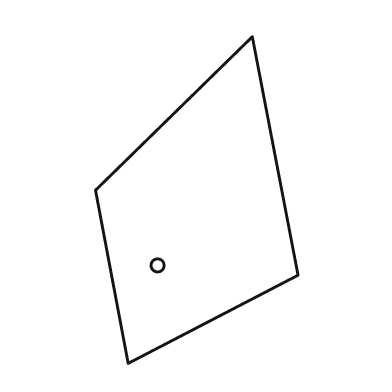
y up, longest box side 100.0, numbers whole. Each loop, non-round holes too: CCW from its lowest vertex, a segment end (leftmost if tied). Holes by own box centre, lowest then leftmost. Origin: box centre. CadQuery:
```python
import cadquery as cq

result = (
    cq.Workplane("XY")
    .moveTo(-21.0, -50.0)
    .lineTo(31.0, -23.0)
    .lineTo(17.0, 50.0)
    .lineTo(-31.0, 3.0)
    .close()
    .moveTo(-12.0, -20.0)
    .circle(2.0)
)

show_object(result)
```